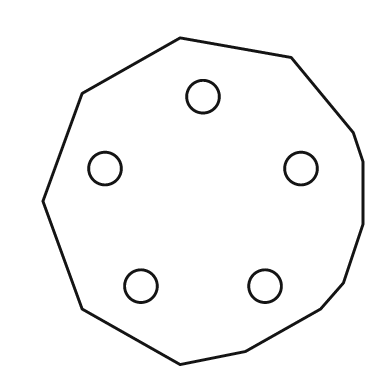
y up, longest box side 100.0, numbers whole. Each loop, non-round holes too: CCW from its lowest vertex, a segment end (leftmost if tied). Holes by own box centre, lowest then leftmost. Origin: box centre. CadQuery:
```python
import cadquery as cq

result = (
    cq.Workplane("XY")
    .moveTo(-7.0, -50.0)
    .lineTo(13.0, -46.0)
    .lineTo(36.0, -33.0)
    .lineTo(43.0, -25.0)
    .lineTo(49.0, -7.0)
    .lineTo(49.0, 12.0)
    .lineTo(46.0, 21.0)
    .lineTo(27.0, 44.0)
    .lineTo(-7.0, 50.0)
    .lineTo(-37.0, 33.0)
    .lineTo(-49.0, 0.0)
    .lineTo(-37.0, -33.0)
    .close()
    .moveTo(-19.0, -26.0)
    .circle(5.0)
    .moveTo(19.0, -26.0)
    .circle(5.0)
    .moveTo(-30.0, 10.0)
    .circle(5.0)
    .moveTo(30.0, 10.0)
    .circle(5.0)
    .moveTo(0.0, 32.0)
    .circle(5.0)
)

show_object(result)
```